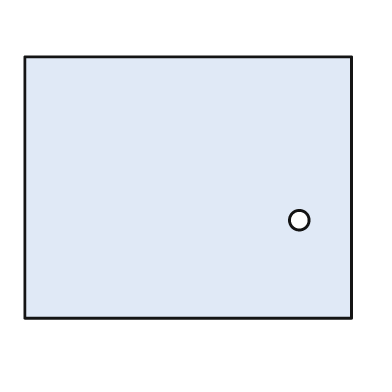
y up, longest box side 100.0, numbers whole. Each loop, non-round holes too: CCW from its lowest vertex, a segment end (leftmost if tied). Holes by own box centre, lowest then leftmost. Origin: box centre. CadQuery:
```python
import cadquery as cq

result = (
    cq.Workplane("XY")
    .moveTo(-50.0, -40.0)
    .lineTo(50.0, -40.0)
    .lineTo(50.0, 40.0)
    .lineTo(-50.0, 40.0)
    .close()
    .moveTo(34.0, -10.0)
    .circle(3.0)
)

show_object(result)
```